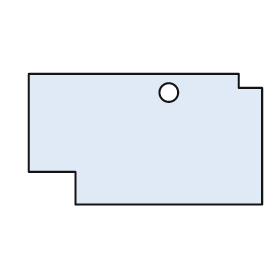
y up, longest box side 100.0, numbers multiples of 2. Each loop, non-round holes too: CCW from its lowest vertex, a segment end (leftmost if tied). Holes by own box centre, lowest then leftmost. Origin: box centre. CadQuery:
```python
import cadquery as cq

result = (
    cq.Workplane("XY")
    .moveTo(-30.0, -28.0)
    .lineTo(50.0, -28.0)
    .lineTo(50.0, 22.0)
    .lineTo(40.0, 22.0)
    .lineTo(40.0, 28.0)
    .lineTo(-50.0, 28.0)
    .lineTo(-50.0, -14.0)
    .lineTo(-30.0, -14.0)
    .close()
    .moveTo(10.0, 20.0)
    .circle(4.0)
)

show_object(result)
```